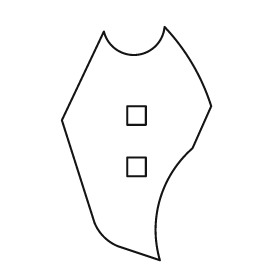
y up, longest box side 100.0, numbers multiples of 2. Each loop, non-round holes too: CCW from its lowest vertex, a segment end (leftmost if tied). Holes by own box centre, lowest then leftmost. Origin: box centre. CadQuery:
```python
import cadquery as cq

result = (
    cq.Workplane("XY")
    .moveTo(10.0, -50.0)
    .threePointArc((10.0, -24.0), (24.0, -2.0))
    .lineTo(32.0, 16.0)
    .threePointArc((24.0, 34.0), (12.0, 50.0))
    .threePointArc((0.0, 38.0), (-14.0, 48.0))
    .lineTo(-32.0, 10.0)
    .lineTo(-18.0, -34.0)
    .threePointArc((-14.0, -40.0), (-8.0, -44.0))
    .close()
    .moveTo(-4.0, -14.0)
    .lineTo(4.0, -14.0)
    .lineTo(4.0, -6.0)
    .lineTo(-4.0, -6.0)
    .close()
    .moveTo(-4.0, 8.0)
    .lineTo(4.0, 8.0)
    .lineTo(4.0, 16.0)
    .lineTo(-4.0, 16.0)
    .close()
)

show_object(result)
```